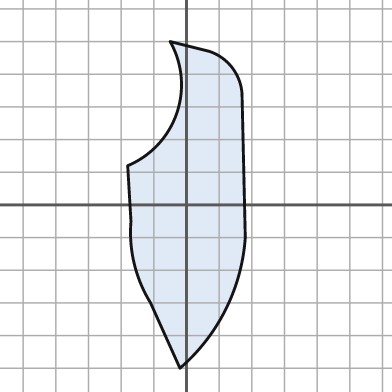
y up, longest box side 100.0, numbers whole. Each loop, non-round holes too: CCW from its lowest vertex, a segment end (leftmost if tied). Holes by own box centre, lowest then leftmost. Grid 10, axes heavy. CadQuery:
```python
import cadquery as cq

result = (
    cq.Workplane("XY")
    .moveTo(-2.0, -50.0)
    .threePointArc((12.0, -32.0), (18.0, -10.0))
    .lineTo(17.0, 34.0)
    .threePointArc((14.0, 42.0), (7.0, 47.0))
    .lineTo(-5.0, 50.0)
    .threePointArc((-3.0, 28.0), (-18.0, 12.0))
    .lineTo(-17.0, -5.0)
    .threePointArc((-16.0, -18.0), (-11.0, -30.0))
    .close()
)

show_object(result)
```